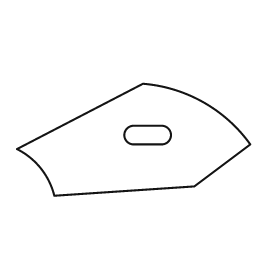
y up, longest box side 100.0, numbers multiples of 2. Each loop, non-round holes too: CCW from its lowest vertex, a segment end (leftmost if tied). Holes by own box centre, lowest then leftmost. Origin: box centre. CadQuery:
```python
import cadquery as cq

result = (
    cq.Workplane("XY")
    .moveTo(-34.0, -24.0)
    .lineTo(26.0, -20.0)
    .lineTo(50.0, -2.0)
    .threePointArc((30.0, 16.0), (4.0, 24.0))
    .lineTo(-50.0, -4.0)
    .threePointArc((-40.0, -12.0), (-34.0, -24.0))
    .close()
    .moveTo(0.0, -2.0)
    .lineTo(12.0, -2.0)
    .threePointArc((16.0, 2.0), (12.0, 6.0))
    .lineTo(0.0, 6.0)
    .threePointArc((-4.0, 2.0), (0.0, -2.0))
    .close()
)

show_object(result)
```